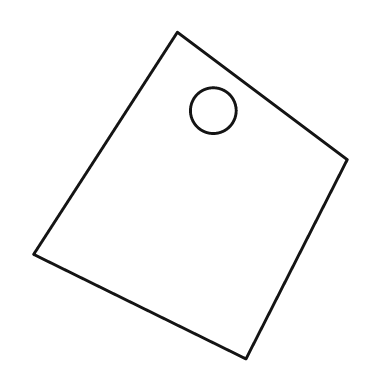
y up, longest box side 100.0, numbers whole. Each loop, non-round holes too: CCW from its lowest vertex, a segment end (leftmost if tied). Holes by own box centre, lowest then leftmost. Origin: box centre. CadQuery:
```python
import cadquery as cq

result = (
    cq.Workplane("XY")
    .moveTo(17.0, -50.0)
    .lineTo(48.0, 11.0)
    .lineTo(-4.0, 50.0)
    .lineTo(-48.0, -18.0)
    .close()
    .moveTo(7.0, 26.0)
    .circle(7.0)
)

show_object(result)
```